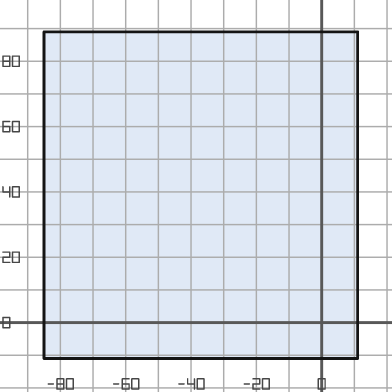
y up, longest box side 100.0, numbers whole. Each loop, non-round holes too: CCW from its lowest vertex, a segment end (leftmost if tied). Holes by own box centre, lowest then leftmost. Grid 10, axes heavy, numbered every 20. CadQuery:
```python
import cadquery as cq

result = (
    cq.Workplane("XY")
    .moveTo(-85.0, -11.0)
    .lineTo(11.0, -11.0)
    .lineTo(11.0, 89.0)
    .lineTo(-85.0, 89.0)
    .close()
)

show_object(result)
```